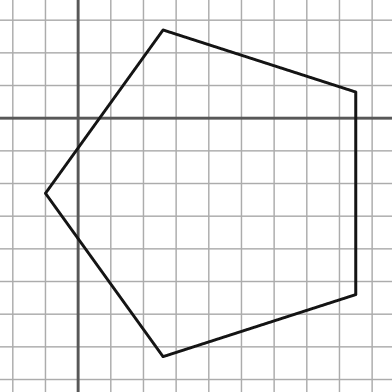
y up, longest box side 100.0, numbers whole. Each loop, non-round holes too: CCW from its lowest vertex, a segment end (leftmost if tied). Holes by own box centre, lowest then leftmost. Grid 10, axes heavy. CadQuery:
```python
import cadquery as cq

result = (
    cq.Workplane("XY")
    .moveTo(26.0, -73.0)
    .lineTo(85.0, -54.0)
    .lineTo(85.0, 8.0)
    .lineTo(26.0, 27.0)
    .lineTo(-10.0, -23.0)
    .close()
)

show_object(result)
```